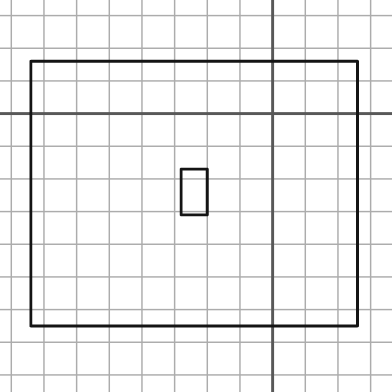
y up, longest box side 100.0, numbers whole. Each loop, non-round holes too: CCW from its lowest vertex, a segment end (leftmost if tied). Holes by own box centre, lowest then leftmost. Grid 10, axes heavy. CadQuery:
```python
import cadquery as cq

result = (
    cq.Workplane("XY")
    .moveTo(-74.0, -65.0)
    .lineTo(26.0, -65.0)
    .lineTo(26.0, 16.0)
    .lineTo(-74.0, 16.0)
    .close()
    .moveTo(-28.0, -31.0)
    .lineTo(-20.0, -31.0)
    .lineTo(-20.0, -17.0)
    .lineTo(-28.0, -17.0)
    .close()
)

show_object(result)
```